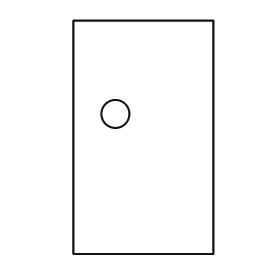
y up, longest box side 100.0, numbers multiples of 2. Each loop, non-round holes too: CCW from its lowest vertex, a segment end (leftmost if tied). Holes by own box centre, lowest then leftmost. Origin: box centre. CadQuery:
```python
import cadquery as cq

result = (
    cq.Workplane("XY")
    .moveTo(-30.0, -50.0)
    .lineTo(30.0, -50.0)
    .lineTo(30.0, 50.0)
    .lineTo(-30.0, 50.0)
    .close()
    .moveTo(-12.0, 10.0)
    .circle(6.0)
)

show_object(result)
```